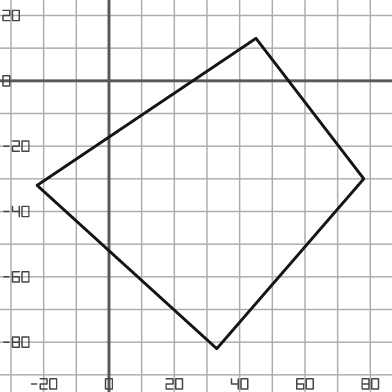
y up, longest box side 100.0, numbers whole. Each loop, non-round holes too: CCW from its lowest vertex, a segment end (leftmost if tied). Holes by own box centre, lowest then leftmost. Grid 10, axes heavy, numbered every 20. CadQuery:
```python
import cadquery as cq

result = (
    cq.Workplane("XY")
    .moveTo(33.0, -82.0)
    .lineTo(78.0, -30.0)
    .lineTo(45.0, 13.0)
    .lineTo(-22.0, -32.0)
    .close()
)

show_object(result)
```